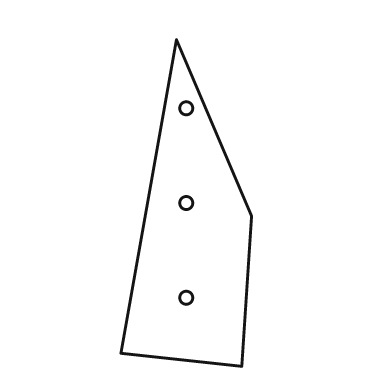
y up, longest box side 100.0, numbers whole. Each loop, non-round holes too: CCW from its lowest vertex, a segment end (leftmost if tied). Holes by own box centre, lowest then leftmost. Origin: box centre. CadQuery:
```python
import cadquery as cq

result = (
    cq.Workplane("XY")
    .moveTo(17.0, -50.0)
    .lineTo(20.0, -4.0)
    .lineTo(-3.0, 50.0)
    .lineTo(-20.0, -46.0)
    .close()
    .moveTo(0.0, -29.0)
    .circle(2.0)
    .moveTo(0.0, 0.0)
    .circle(2.0)
    .moveTo(0.0, 29.0)
    .circle(2.0)
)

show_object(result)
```